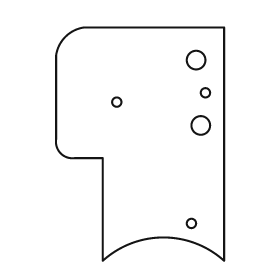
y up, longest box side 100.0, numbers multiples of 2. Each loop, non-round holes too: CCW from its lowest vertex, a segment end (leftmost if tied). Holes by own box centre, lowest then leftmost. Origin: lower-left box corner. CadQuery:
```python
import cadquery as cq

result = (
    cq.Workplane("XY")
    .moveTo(20.0, 0.0)
    .threePointArc((46.0, 10.0), (72.0, 0.0))
    .lineTo(72.0, 100.0)
    .lineTo(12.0, 100.0)
    .threePointArc((4.0, 96.0), (0.0, 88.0))
    .lineTo(0.0, 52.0)
    .threePointArc((2.0, 46.0), (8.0, 44.0))
    .lineTo(20.0, 44.0)
    .close()
    .moveTo(58.0, 16.0)
    .circle(2.0)
    .moveTo(62.0, 58.0)
    .circle(4.0)
    .moveTo(26.0, 68.0)
    .circle(2.0)
    .moveTo(64.0, 72.0)
    .circle(2.0)
    .moveTo(60.0, 86.0)
    .circle(4.0)
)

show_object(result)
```